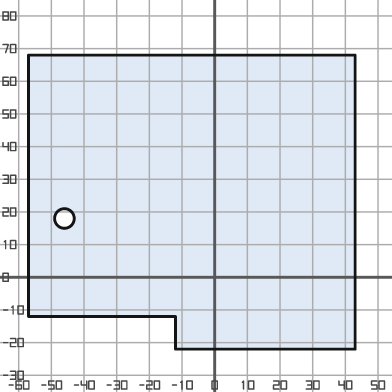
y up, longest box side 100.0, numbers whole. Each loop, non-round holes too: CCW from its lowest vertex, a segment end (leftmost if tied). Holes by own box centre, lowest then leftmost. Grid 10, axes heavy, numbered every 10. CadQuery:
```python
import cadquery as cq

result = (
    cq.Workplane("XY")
    .moveTo(-12.0, -22.0)
    .lineTo(43.0, -22.0)
    .lineTo(43.0, 68.0)
    .lineTo(-57.0, 68.0)
    .lineTo(-57.0, -12.0)
    .lineTo(-12.0, -12.0)
    .close()
    .moveTo(-46.0, 18.0)
    .circle(3.0)
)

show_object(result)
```